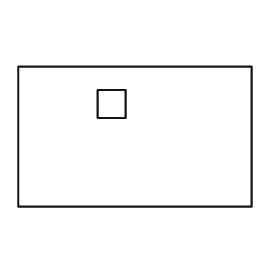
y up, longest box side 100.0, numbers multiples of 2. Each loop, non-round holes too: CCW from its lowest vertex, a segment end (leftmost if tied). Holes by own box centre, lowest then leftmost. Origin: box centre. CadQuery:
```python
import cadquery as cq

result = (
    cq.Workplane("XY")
    .moveTo(-50.0, -30.0)
    .lineTo(50.0, -30.0)
    .lineTo(50.0, 30.0)
    .lineTo(-50.0, 30.0)
    .close()
    .moveTo(-16.0, 8.0)
    .lineTo(-4.0, 8.0)
    .lineTo(-4.0, 20.0)
    .lineTo(-16.0, 20.0)
    .close()
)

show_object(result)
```